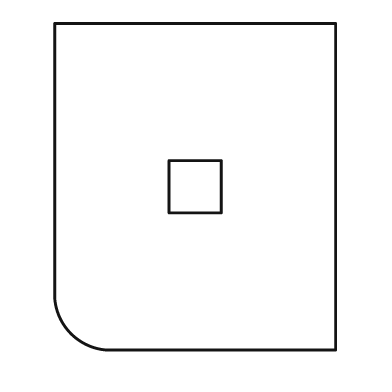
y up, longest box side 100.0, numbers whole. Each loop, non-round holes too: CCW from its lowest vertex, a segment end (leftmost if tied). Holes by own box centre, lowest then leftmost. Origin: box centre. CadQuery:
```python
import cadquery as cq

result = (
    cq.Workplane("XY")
    .moveTo(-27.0, -50.0)
    .lineTo(43.0, -50.0)
    .lineTo(43.0, 50.0)
    .lineTo(-43.0, 50.0)
    .lineTo(-43.0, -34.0)
    .threePointArc((-38.0, -45.0), (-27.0, -50.0))
    .close()
    .moveTo(-8.0, -8.0)
    .lineTo(8.0, -8.0)
    .lineTo(8.0, 8.0)
    .lineTo(-8.0, 8.0)
    .close()
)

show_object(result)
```